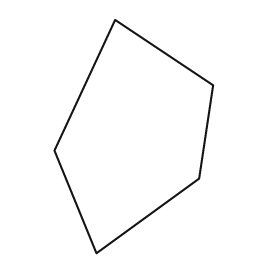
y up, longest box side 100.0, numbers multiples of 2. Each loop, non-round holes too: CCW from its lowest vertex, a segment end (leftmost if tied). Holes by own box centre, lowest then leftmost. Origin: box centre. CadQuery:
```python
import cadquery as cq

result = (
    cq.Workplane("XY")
    .moveTo(-16.0, -50.0)
    .lineTo(28.0, -18.0)
    .lineTo(34.0, 22.0)
    .lineTo(-8.0, 50.0)
    .lineTo(-34.0, -6.0)
    .close()
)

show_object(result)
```